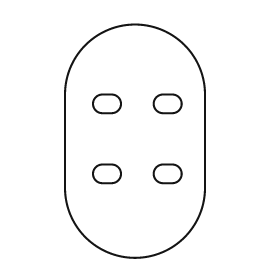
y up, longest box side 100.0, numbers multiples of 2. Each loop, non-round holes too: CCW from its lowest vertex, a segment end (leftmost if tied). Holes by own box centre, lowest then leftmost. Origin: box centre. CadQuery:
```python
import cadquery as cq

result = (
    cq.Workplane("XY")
    .moveTo(-30.0, -20.0)
    .threePointArc((0.0, -50.0), (30.0, -20.0))
    .lineTo(30.0, 20.0)
    .threePointArc((0.0, 50.0), (-30.0, 20.0))
    .close()
    .moveTo(-14.0, -18.0)
    .lineTo(-10.0, -18.0)
    .threePointArc((-6.0, -14.0), (-10.0, -10.0))
    .lineTo(-14.0, -10.0)
    .threePointArc((-18.0, -14.0), (-14.0, -18.0))
    .close()
    .moveTo(12.0, -18.0)
    .lineTo(16.0, -18.0)
    .threePointArc((20.0, -14.0), (16.0, -10.0))
    .lineTo(12.0, -10.0)
    .threePointArc((8.0, -14.0), (12.0, -18.0))
    .close()
    .moveTo(-14.0, 12.0)
    .lineTo(-10.0, 12.0)
    .threePointArc((-6.0, 16.0), (-10.0, 20.0))
    .lineTo(-14.0, 20.0)
    .threePointArc((-18.0, 16.0), (-14.0, 12.0))
    .close()
    .moveTo(12.0, 12.0)
    .lineTo(16.0, 12.0)
    .threePointArc((20.0, 16.0), (16.0, 20.0))
    .lineTo(12.0, 20.0)
    .threePointArc((8.0, 16.0), (12.0, 12.0))
    .close()
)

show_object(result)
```